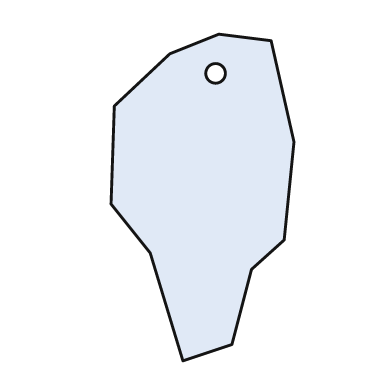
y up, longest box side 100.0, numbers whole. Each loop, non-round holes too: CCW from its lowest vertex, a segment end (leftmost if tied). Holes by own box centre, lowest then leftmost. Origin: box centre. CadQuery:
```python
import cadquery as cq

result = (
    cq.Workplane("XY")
    .moveTo(-6.0, -50.0)
    .lineTo(9.0, -45.0)
    .lineTo(15.0, -22.0)
    .lineTo(25.0, -13.0)
    .lineTo(28.0, 17.0)
    .lineTo(21.0, 48.0)
    .lineTo(5.0, 50.0)
    .lineTo(-10.0, 44.0)
    .lineTo(-27.0, 28.0)
    .lineTo(-28.0, -2.0)
    .lineTo(-16.0, -17.0)
    .close()
    .moveTo(4.0, 38.0)
    .circle(3.0)
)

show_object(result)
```